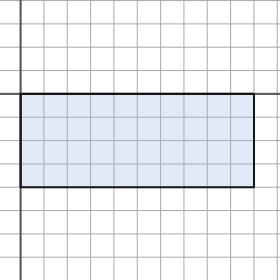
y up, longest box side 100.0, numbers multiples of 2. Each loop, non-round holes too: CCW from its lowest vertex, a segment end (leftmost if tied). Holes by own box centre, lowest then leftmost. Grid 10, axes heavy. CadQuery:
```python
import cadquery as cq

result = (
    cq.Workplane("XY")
    .moveTo(0.0, -40.0)
    .lineTo(100.0, -40.0)
    .lineTo(100.0, 0.0)
    .lineTo(0.0, 0.0)
    .close()
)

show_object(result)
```